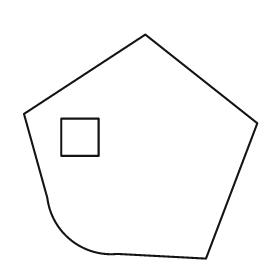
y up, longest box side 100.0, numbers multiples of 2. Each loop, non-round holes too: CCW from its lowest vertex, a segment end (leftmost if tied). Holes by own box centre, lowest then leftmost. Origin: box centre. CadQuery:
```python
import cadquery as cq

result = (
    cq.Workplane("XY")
    .moveTo(28.0, -48.0)
    .lineTo(50.0, 10.0)
    .lineTo(2.0, 48.0)
    .lineTo(-50.0, 14.0)
    .lineTo(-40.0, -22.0)
    .threePointArc((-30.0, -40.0), (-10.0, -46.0))
    .close()
    .moveTo(-34.0, -4.0)
    .lineTo(-18.0, -4.0)
    .lineTo(-18.0, 12.0)
    .lineTo(-34.0, 12.0)
    .close()
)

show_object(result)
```